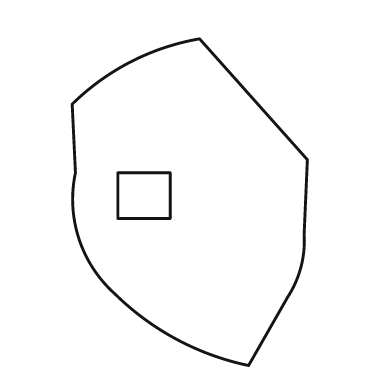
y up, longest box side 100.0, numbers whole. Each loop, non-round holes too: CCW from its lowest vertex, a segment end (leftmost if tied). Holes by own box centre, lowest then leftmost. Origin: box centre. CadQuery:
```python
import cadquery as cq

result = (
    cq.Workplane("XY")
    .moveTo(18.0, -50.0)
    .lineTo(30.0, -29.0)
    .threePointArc((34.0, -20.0), (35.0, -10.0))
    .lineTo(36.0, 13.0)
    .lineTo(3.0, 50.0)
    .threePointArc((-18.0, 43.0), (-36.0, 30.0))
    .lineTo(-35.0, 9.0)
    .threePointArc((-34.0, -11.0), (-23.0, -28.0))
    .threePointArc((-4.0, -42.0), (18.0, -50.0))
    .close()
    .moveTo(-22.0, -5.0)
    .lineTo(-6.0, -5.0)
    .lineTo(-6.0, 9.0)
    .lineTo(-22.0, 9.0)
    .close()
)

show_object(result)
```